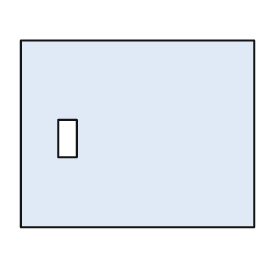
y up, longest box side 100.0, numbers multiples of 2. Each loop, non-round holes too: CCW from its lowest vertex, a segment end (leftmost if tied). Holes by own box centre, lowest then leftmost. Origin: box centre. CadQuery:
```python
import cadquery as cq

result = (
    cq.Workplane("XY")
    .moveTo(-50.0, -40.0)
    .lineTo(50.0, -40.0)
    .lineTo(50.0, 40.0)
    .lineTo(-50.0, 40.0)
    .close()
    .moveTo(-34.0, -10.0)
    .lineTo(-26.0, -10.0)
    .lineTo(-26.0, 6.0)
    .lineTo(-34.0, 6.0)
    .close()
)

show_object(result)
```